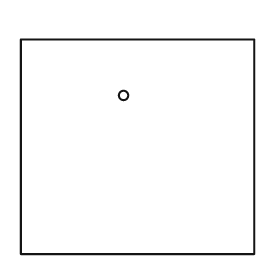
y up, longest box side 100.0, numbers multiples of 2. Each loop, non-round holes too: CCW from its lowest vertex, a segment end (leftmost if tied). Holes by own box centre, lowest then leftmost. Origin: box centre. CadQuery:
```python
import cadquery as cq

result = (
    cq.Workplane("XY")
    .moveTo(-50.0, -46.0)
    .lineTo(50.0, -46.0)
    .lineTo(50.0, 46.0)
    .lineTo(-50.0, 46.0)
    .close()
    .moveTo(-6.0, 22.0)
    .circle(2.0)
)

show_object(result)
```